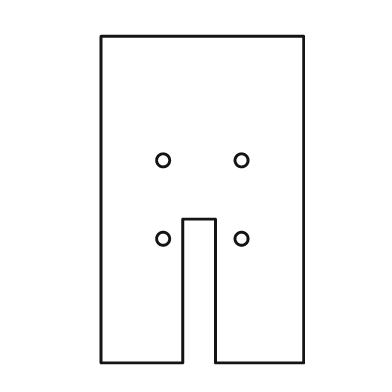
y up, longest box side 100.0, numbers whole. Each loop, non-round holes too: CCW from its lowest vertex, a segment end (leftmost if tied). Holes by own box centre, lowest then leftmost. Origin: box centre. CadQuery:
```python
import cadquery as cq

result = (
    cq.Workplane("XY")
    .moveTo(-31.0, -50.0)
    .lineTo(-6.0, -50.0)
    .lineTo(-6.0, -6.0)
    .lineTo(4.0, -6.0)
    .lineTo(4.0, -50.0)
    .lineTo(31.0, -50.0)
    .lineTo(31.0, 50.0)
    .lineTo(-31.0, 50.0)
    .close()
    .moveTo(-12.0, -12.0)
    .circle(2.0)
    .moveTo(12.0, -12.0)
    .circle(2.0)
    .moveTo(-12.0, 12.0)
    .circle(2.0)
    .moveTo(12.0, 12.0)
    .circle(2.0)
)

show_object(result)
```